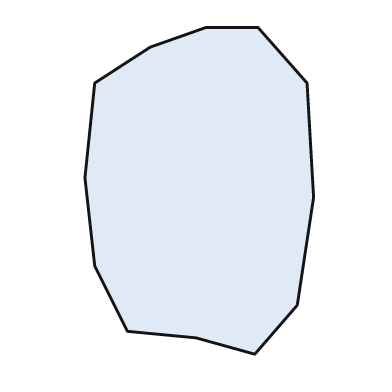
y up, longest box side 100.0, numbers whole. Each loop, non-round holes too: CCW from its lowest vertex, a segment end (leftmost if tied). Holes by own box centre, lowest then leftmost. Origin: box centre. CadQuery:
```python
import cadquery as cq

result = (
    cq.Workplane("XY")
    .moveTo(17.0, -50.0)
    .lineTo(30.0, -35.0)
    .lineTo(35.0, -2.0)
    .lineTo(33.0, 33.0)
    .lineTo(18.0, 50.0)
    .lineTo(2.0, 50.0)
    .lineTo(-15.0, 44.0)
    .lineTo(-32.0, 33.0)
    .lineTo(-35.0, 4.0)
    .lineTo(-32.0, -23.0)
    .lineTo(-22.0, -43.0)
    .lineTo(-1.0, -45.0)
    .close()
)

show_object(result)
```